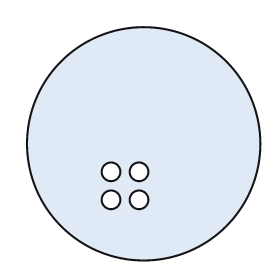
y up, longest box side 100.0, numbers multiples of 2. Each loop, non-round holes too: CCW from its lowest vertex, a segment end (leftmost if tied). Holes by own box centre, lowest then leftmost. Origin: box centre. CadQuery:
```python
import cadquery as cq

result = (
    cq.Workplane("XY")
    .moveTo(0.0, 0.0)
    .circle(50.0)
    .moveTo(-14.0, -24.0)
    .circle(4.0)
    .moveTo(-2.0, -24.0)
    .circle(4.0)
    .moveTo(-14.0, -12.0)
    .circle(4.0)
    .moveTo(-2.0, -12.0)
    .circle(4.0)
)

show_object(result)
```